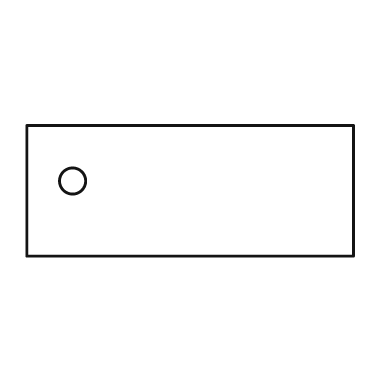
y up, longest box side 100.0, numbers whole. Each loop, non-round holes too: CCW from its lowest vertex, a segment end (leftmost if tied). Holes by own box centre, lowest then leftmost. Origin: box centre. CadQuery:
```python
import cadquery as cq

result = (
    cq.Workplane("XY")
    .moveTo(-50.0, -20.0)
    .lineTo(50.0, -20.0)
    .lineTo(50.0, 20.0)
    .lineTo(-50.0, 20.0)
    .close()
    .moveTo(-36.0, 3.0)
    .circle(4.0)
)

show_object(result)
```